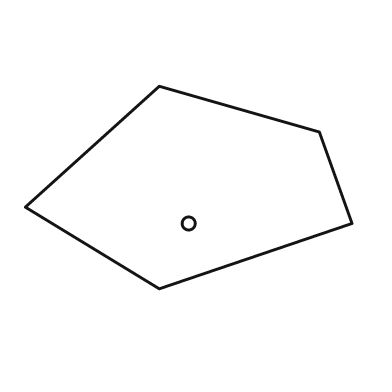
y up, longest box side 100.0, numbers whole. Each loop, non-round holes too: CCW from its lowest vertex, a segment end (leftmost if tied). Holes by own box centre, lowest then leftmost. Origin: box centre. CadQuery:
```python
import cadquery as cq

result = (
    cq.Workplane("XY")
    .moveTo(-9.0, -31.0)
    .lineTo(50.0, -11.0)
    .lineTo(40.0, 17.0)
    .lineTo(-9.0, 31.0)
    .lineTo(-50.0, -6.0)
    .close()
    .moveTo(0.0, -11.0)
    .circle(2.0)
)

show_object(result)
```